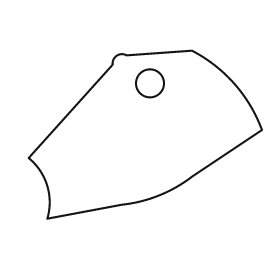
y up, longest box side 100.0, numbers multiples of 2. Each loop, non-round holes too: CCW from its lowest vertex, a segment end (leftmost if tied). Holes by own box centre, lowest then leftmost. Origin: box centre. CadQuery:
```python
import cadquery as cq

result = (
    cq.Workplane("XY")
    .moveTo(-42.0, -36.0)
    .lineTo(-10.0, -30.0)
    .threePointArc((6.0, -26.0), (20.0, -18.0))
    .lineTo(50.0, 2.0)
    .threePointArc((38.0, 22.0), (20.0, 36.0))
    .lineTo(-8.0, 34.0)
    .threePointArc((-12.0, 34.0), (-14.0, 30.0))
    .lineTo(-50.0, -10.0)
    .threePointArc((-42.0, -22.0), (-42.0, -36.0))
    .close()
    .moveTo(2.0, 22.0)
    .circle(6.0)
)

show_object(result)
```